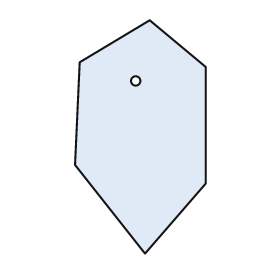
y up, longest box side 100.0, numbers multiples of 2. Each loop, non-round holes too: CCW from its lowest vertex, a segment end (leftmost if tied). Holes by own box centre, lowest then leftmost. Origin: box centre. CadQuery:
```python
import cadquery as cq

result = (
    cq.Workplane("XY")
    .moveTo(2.0, -50.0)
    .lineTo(28.0, -20.0)
    .lineTo(28.0, 30.0)
    .lineTo(4.0, 50.0)
    .lineTo(-26.0, 32.0)
    .lineTo(-28.0, -12.0)
    .close()
    .moveTo(-2.0, 24.0)
    .circle(2.0)
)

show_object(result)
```